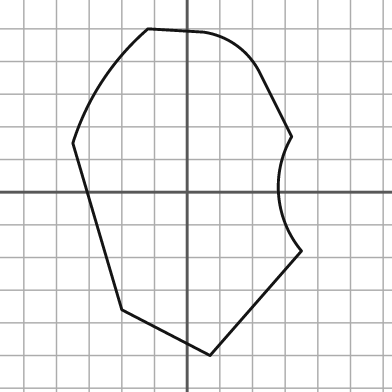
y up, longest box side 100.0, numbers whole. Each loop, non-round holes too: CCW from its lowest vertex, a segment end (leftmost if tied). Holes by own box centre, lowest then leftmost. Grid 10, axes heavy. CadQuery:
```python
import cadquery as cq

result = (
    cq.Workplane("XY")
    .moveTo(7.0, -50.0)
    .lineTo(35.0, -18.0)
    .threePointArc((28.0, -1.0), (32.0, 17.0))
    .lineTo(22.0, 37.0)
    .threePointArc((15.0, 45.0), (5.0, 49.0))
    .lineTo(-12.0, 50.0)
    .threePointArc((-26.0, 34.0), (-35.0, 15.0))
    .lineTo(-20.0, -36.0)
    .close()
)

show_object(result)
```